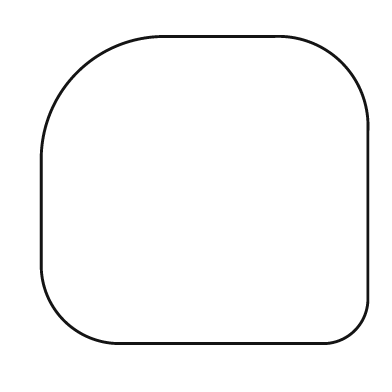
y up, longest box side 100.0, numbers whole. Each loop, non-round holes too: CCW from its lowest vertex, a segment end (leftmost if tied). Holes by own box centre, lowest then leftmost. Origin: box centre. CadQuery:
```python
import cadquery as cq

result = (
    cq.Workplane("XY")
    .moveTo(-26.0, -47.0)
    .lineTo(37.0, -47.0)
    .threePointArc((46.0, -43.0), (50.0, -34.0))
    .lineTo(50.0, 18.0)
    .threePointArc((42.0, 39.0), (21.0, 47.0))
    .lineTo(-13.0, 47.0)
    .threePointArc((-39.0, 36.0), (-50.0, 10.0))
    .lineTo(-50.0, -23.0)
    .threePointArc((-43.0, -40.0), (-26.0, -47.0))
    .close()
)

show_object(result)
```